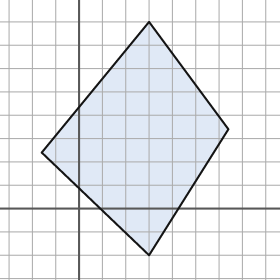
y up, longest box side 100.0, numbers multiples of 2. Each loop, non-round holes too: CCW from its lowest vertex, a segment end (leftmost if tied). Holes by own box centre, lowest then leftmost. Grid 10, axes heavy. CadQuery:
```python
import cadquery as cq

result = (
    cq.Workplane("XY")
    .moveTo(30.0, -20.0)
    .lineTo(64.0, 34.0)
    .lineTo(30.0, 80.0)
    .lineTo(-16.0, 24.0)
    .close()
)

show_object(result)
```